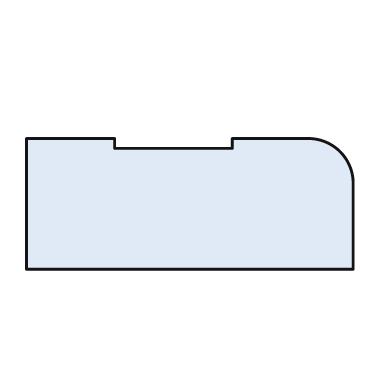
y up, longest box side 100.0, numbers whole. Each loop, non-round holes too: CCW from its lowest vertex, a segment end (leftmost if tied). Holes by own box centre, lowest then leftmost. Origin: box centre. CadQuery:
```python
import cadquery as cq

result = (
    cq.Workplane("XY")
    .moveTo(-50.0, -20.0)
    .lineTo(50.0, -20.0)
    .lineTo(50.0, 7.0)
    .threePointArc((46.0, 16.0), (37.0, 20.0))
    .lineTo(13.0, 20.0)
    .lineTo(13.0, 17.0)
    .lineTo(-23.0, 17.0)
    .lineTo(-23.0, 20.0)
    .lineTo(-50.0, 20.0)
    .close()
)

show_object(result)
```